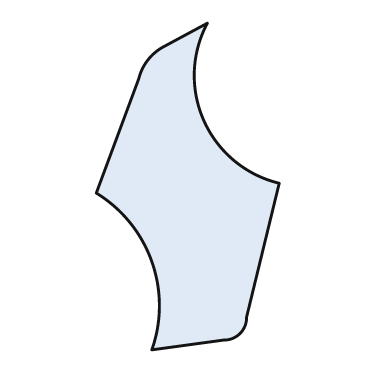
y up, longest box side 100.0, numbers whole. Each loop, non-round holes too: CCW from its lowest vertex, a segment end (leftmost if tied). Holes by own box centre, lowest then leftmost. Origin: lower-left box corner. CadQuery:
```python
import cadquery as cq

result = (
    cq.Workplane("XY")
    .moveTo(17.0, 0.0)
    .lineTo(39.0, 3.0)
    .threePointArc((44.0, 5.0), (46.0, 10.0))
    .lineTo(56.0, 51.0)
    .threePointArc((33.0, 70.0), (34.0, 100.0))
    .lineTo(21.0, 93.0)
    .threePointArc((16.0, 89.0), (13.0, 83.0))
    .lineTo(0.0, 48.0)
    .threePointArc((17.0, 27.0), (17.0, 0.0))
    .close()
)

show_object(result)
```